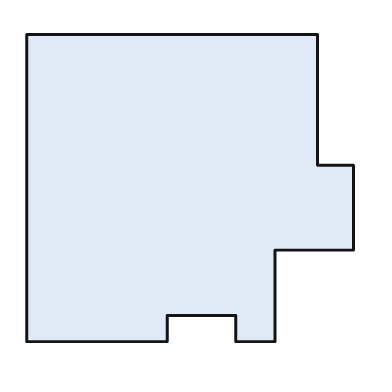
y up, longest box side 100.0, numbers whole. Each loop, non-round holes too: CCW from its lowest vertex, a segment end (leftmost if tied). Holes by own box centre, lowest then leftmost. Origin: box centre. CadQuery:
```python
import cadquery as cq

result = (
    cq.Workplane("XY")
    .moveTo(-50.0, -47.0)
    .lineTo(-7.0, -47.0)
    .lineTo(-7.0, -39.0)
    .lineTo(14.0, -39.0)
    .lineTo(14.0, -47.0)
    .lineTo(26.0, -47.0)
    .lineTo(26.0, -19.0)
    .lineTo(50.0, -19.0)
    .lineTo(50.0, 7.0)
    .lineTo(39.0, 7.0)
    .lineTo(39.0, 47.0)
    .lineTo(-50.0, 47.0)
    .close()
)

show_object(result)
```